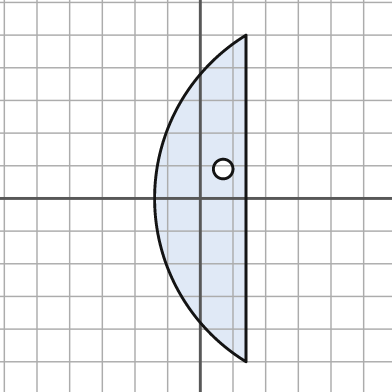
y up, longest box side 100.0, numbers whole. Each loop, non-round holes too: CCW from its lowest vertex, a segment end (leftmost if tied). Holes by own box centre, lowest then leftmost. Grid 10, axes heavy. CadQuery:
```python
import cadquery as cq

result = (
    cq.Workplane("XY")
    .moveTo(14.0, -50.0)
    .lineTo(14.0, 50.0)
    .threePointArc((-14.0, 0.0), (14.0, -50.0))
    .close()
    .moveTo(7.0, 9.0)
    .circle(3.0)
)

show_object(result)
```